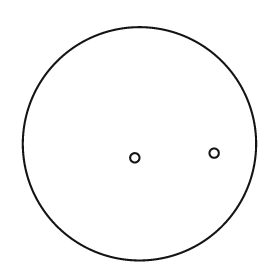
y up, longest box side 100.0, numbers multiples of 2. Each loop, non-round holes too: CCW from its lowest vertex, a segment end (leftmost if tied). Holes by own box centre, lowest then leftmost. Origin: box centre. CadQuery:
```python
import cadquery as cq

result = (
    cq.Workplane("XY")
    .moveTo(0.0, 0.0)
    .circle(50.0)
    .moveTo(-2.0, -6.0)
    .circle(2.0)
    .moveTo(32.0, -4.0)
    .circle(2.0)
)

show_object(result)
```